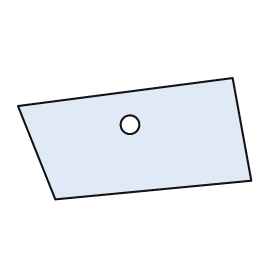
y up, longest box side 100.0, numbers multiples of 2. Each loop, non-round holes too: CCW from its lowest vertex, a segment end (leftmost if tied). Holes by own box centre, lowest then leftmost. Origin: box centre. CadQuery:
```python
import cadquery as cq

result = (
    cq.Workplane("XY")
    .moveTo(-34.0, -26.0)
    .lineTo(50.0, -18.0)
    .lineTo(42.0, 26.0)
    .lineTo(-50.0, 14.0)
    .close()
    .moveTo(-2.0, 6.0)
    .circle(4.0)
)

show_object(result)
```